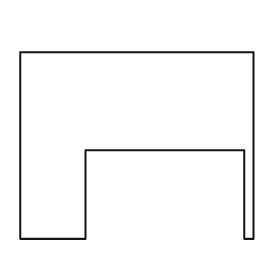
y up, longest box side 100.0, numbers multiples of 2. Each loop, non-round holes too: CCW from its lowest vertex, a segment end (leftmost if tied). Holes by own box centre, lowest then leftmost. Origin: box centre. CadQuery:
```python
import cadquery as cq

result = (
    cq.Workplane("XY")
    .moveTo(-50.0, -40.0)
    .lineTo(-22.0, -40.0)
    .lineTo(-22.0, -2.0)
    .lineTo(46.0, -2.0)
    .lineTo(46.0, -40.0)
    .lineTo(50.0, -40.0)
    .lineTo(50.0, 40.0)
    .lineTo(-50.0, 40.0)
    .close()
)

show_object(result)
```